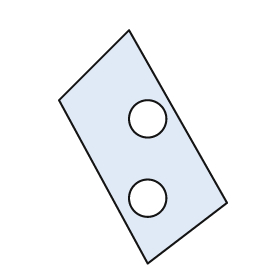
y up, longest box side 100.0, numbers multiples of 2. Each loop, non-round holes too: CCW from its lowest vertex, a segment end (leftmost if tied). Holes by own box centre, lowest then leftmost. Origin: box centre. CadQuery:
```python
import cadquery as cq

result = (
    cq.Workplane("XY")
    .moveTo(2.0, -50.0)
    .lineTo(36.0, -24.0)
    .lineTo(-6.0, 50.0)
    .lineTo(-36.0, 20.0)
    .close()
    .moveTo(2.0, -22.0)
    .circle(8.0)
    .moveTo(2.0, 12.0)
    .circle(8.0)
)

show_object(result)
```